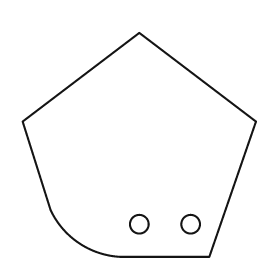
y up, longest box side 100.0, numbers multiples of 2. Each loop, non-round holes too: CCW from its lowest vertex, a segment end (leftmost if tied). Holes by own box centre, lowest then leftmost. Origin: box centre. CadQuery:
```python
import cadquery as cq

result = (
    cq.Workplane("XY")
    .moveTo(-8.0, -48.0)
    .lineTo(30.0, -48.0)
    .lineTo(50.0, 10.0)
    .lineTo(0.0, 48.0)
    .lineTo(-50.0, 10.0)
    .lineTo(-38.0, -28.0)
    .threePointArc((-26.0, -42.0), (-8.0, -48.0))
    .close()
    .moveTo(0.0, -34.0)
    .circle(4.0)
    .moveTo(22.0, -34.0)
    .circle(4.0)
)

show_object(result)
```